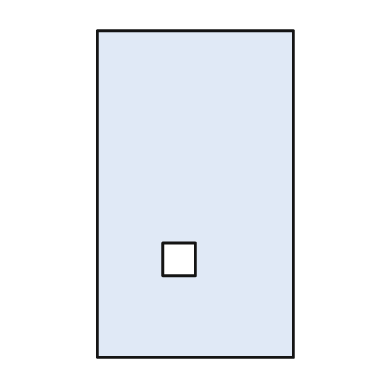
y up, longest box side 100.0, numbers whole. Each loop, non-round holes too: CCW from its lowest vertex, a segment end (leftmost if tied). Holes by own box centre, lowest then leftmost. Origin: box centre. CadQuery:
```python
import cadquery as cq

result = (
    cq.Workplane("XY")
    .moveTo(-30.0, -50.0)
    .lineTo(30.0, -50.0)
    .lineTo(30.0, 50.0)
    .lineTo(-30.0, 50.0)
    .close()
    .moveTo(-10.0, -25.0)
    .lineTo(0.0, -25.0)
    .lineTo(0.0, -15.0)
    .lineTo(-10.0, -15.0)
    .close()
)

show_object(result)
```